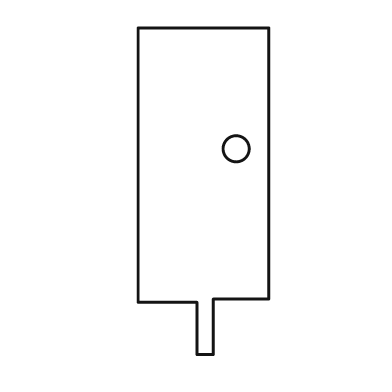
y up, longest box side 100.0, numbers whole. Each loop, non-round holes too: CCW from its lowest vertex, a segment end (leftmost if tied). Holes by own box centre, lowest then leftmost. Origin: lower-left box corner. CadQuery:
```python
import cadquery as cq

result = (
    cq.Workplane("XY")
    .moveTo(18.0, 0.0)
    .lineTo(23.0, 0.0)
    .lineTo(23.0, 17.0)
    .lineTo(40.0, 17.0)
    .lineTo(40.0, 100.0)
    .lineTo(0.0, 100.0)
    .lineTo(0.0, 16.0)
    .lineTo(18.0, 16.0)
    .close()
    .moveTo(30.0, 63.0)
    .circle(4.0)
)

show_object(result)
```